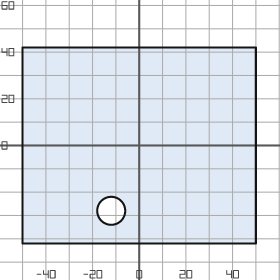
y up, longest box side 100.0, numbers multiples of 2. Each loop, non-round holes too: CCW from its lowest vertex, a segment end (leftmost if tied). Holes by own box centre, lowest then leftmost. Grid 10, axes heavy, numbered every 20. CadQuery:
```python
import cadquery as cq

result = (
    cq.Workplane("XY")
    .moveTo(-50.0, -42.0)
    .lineTo(50.0, -42.0)
    .lineTo(50.0, 42.0)
    .lineTo(-50.0, 42.0)
    .close()
    .moveTo(-12.0, -28.0)
    .circle(6.0)
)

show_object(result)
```